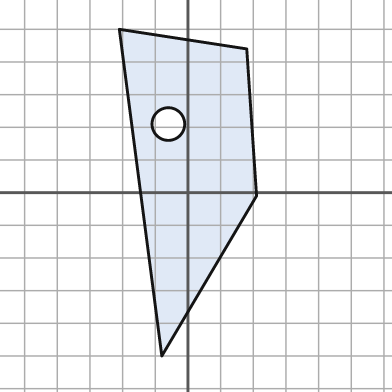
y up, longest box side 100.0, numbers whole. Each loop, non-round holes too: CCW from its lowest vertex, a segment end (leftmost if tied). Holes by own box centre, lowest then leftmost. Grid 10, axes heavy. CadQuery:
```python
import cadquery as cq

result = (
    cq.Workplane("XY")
    .moveTo(-8.0, -50.0)
    .lineTo(21.0, -1.0)
    .lineTo(18.0, 44.0)
    .lineTo(-21.0, 50.0)
    .close()
    .moveTo(-6.0, 21.0)
    .circle(5.0)
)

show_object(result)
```